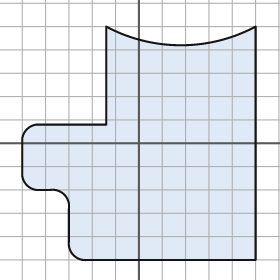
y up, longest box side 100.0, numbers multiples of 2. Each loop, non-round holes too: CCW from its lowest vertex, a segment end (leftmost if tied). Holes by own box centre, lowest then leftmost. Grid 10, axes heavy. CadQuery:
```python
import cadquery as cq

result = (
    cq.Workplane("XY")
    .moveTo(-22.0, -50.0)
    .lineTo(50.0, -50.0)
    .lineTo(50.0, 50.0)
    .threePointArc((18.0, 42.0), (-14.0, 50.0))
    .lineTo(-14.0, 8.0)
    .lineTo(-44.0, 8.0)
    .threePointArc((-48.0, 6.0), (-50.0, 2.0))
    .lineTo(-50.0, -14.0)
    .threePointArc((-48.0, -18.0), (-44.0, -20.0))
    .lineTo(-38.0, -20.0)
    .threePointArc((-32.0, -22.0), (-30.0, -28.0))
    .lineTo(-30.0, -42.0)
    .threePointArc((-28.0, -48.0), (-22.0, -50.0))
    .close()
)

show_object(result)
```